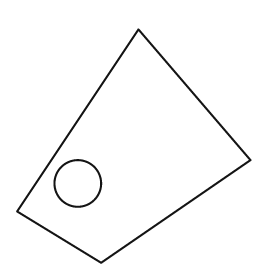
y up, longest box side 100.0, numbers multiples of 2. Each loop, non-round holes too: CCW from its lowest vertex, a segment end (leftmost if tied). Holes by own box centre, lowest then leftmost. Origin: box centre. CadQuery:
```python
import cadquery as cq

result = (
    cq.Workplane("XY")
    .moveTo(-14.0, -50.0)
    .lineTo(50.0, -6.0)
    .lineTo(2.0, 50.0)
    .lineTo(-50.0, -28.0)
    .close()
    .moveTo(-24.0, -16.0)
    .circle(10.0)
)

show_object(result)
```